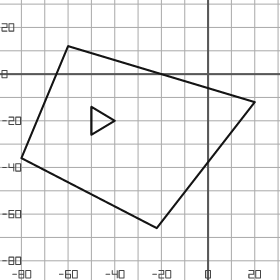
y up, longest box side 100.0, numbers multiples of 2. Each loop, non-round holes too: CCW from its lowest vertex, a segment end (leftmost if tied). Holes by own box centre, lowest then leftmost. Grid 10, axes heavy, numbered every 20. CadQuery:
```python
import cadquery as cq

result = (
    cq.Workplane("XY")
    .moveTo(-22.0, -66.0)
    .lineTo(20.0, -12.0)
    .lineTo(-60.0, 12.0)
    .lineTo(-80.0, -36.0)
    .close()
    .moveTo(-50.0, -26.0)
    .lineTo(-40.0, -20.0)
    .lineTo(-50.0, -14.0)
    .close()
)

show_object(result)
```